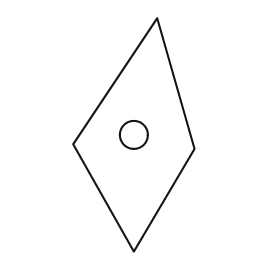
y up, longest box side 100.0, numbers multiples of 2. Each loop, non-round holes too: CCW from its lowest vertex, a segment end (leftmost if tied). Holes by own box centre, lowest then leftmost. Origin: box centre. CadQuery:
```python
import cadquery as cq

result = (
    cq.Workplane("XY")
    .moveTo(0.0, -50.0)
    .lineTo(26.0, -6.0)
    .lineTo(10.0, 50.0)
    .lineTo(-26.0, -4.0)
    .close()
    .moveTo(0.0, 0.0)
    .circle(6.0)
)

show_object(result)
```